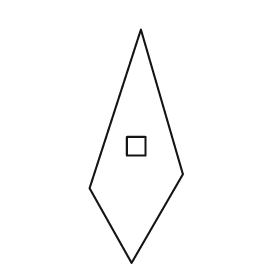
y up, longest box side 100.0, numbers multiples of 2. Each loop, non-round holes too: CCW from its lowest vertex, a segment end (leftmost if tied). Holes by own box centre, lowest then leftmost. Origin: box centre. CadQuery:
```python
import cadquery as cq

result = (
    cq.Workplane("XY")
    .moveTo(-2.0, -50.0)
    .lineTo(20.0, -12.0)
    .lineTo(2.0, 50.0)
    .lineTo(-20.0, -18.0)
    .close()
    .moveTo(-4.0, -4.0)
    .lineTo(4.0, -4.0)
    .lineTo(4.0, 4.0)
    .lineTo(-4.0, 4.0)
    .close()
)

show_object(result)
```